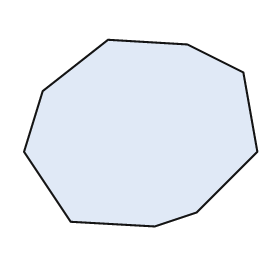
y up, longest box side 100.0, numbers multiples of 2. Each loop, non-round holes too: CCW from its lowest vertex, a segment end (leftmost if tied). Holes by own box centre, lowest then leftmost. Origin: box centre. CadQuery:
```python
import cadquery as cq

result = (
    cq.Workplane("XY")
    .moveTo(6.0, -40.0)
    .lineTo(24.0, -34.0)
    .lineTo(50.0, -8.0)
    .lineTo(44.0, 26.0)
    .lineTo(20.0, 38.0)
    .lineTo(-14.0, 40.0)
    .lineTo(-42.0, 18.0)
    .lineTo(-50.0, -8.0)
    .lineTo(-30.0, -38.0)
    .close()
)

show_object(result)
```